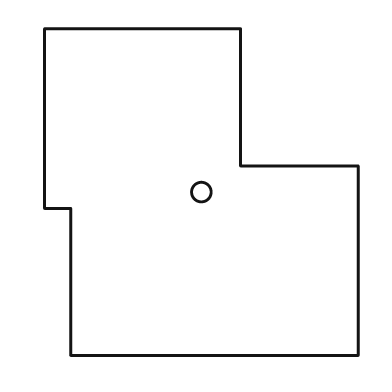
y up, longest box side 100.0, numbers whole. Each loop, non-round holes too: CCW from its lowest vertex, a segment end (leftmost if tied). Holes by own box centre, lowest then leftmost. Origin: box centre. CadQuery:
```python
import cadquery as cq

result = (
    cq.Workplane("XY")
    .moveTo(-40.0, -50.0)
    .lineTo(48.0, -50.0)
    .lineTo(48.0, 8.0)
    .lineTo(12.0, 8.0)
    .lineTo(12.0, 50.0)
    .lineTo(-48.0, 50.0)
    .lineTo(-48.0, -5.0)
    .lineTo(-40.0, -5.0)
    .close()
    .moveTo(0.0, 0.0)
    .circle(3.0)
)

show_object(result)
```